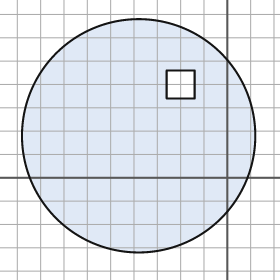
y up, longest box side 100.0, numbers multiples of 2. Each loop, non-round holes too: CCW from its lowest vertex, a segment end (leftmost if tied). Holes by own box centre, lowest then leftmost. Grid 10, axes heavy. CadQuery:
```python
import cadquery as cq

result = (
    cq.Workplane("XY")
    .moveTo(-38.0, 18.0)
    .circle(50.0)
    .moveTo(-26.0, 34.0)
    .lineTo(-14.0, 34.0)
    .lineTo(-14.0, 46.0)
    .lineTo(-26.0, 46.0)
    .close()
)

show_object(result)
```